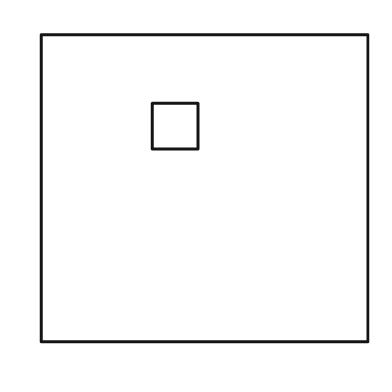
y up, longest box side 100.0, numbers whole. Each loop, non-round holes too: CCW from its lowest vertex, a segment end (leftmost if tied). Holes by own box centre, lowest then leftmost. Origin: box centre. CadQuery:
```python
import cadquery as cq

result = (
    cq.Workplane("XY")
    .moveTo(-50.0, -47.0)
    .lineTo(50.0, -47.0)
    .lineTo(50.0, 47.0)
    .lineTo(-50.0, 47.0)
    .close()
    .moveTo(-16.0, 12.0)
    .lineTo(-2.0, 12.0)
    .lineTo(-2.0, 26.0)
    .lineTo(-16.0, 26.0)
    .close()
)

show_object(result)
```